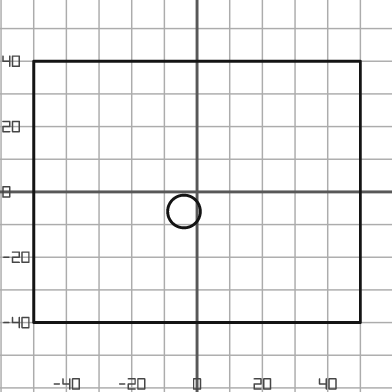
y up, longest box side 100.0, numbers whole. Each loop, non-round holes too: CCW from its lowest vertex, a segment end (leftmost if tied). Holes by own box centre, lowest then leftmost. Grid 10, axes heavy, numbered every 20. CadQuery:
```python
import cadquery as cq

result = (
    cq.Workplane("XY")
    .moveTo(-50.0, -40.0)
    .lineTo(50.0, -40.0)
    .lineTo(50.0, 40.0)
    .lineTo(-50.0, 40.0)
    .close()
    .moveTo(-4.0, -6.0)
    .circle(5.0)
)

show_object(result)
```